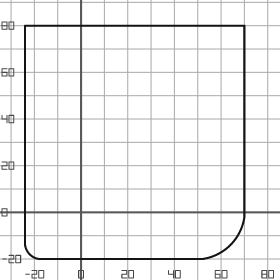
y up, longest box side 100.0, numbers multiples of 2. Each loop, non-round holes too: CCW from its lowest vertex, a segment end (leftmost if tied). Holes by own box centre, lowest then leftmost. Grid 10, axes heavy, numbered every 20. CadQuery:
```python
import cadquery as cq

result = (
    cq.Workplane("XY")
    .moveTo(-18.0, -20.0)
    .lineTo(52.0, -20.0)
    .threePointArc((64.0, -14.0), (70.0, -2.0))
    .lineTo(70.0, 80.0)
    .lineTo(-24.0, 80.0)
    .lineTo(-24.0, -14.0)
    .threePointArc((-22.0, -18.0), (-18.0, -20.0))
    .close()
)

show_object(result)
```